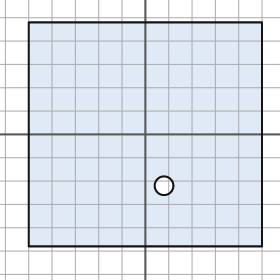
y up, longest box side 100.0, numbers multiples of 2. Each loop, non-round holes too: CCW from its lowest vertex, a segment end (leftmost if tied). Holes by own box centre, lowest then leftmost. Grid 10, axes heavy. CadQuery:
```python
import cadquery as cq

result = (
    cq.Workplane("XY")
    .moveTo(-50.0, -48.0)
    .lineTo(50.0, -48.0)
    .lineTo(50.0, 48.0)
    .lineTo(-50.0, 48.0)
    .close()
    .moveTo(8.0, -22.0)
    .circle(4.0)
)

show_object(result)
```